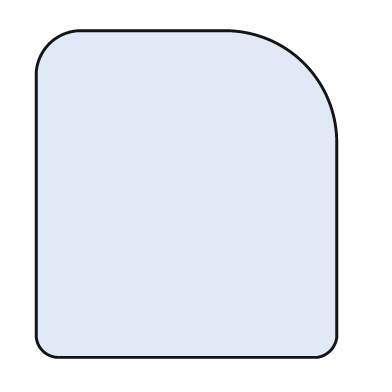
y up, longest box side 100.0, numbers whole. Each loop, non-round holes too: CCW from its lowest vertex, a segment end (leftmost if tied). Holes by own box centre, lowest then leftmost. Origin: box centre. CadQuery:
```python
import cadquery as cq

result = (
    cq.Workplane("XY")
    .moveTo(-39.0, -50.0)
    .lineTo(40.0, -50.0)
    .threePointArc((44.0, -48.0), (46.0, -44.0))
    .lineTo(46.0, 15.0)
    .threePointArc((36.0, 40.0), (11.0, 50.0))
    .lineTo(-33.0, 50.0)
    .threePointArc((-42.0, 46.0), (-46.0, 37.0))
    .lineTo(-46.0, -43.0)
    .threePointArc((-44.0, -48.0), (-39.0, -50.0))
    .close()
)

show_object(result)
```